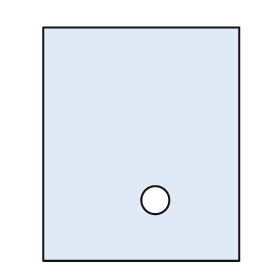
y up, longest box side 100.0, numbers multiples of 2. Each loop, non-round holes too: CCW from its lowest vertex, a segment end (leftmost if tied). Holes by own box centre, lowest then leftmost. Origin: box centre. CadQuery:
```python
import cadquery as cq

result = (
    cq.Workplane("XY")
    .moveTo(-42.0, -50.0)
    .lineTo(42.0, -50.0)
    .lineTo(42.0, 50.0)
    .lineTo(-42.0, 50.0)
    .close()
    .moveTo(6.0, -24.0)
    .circle(6.0)
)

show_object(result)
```